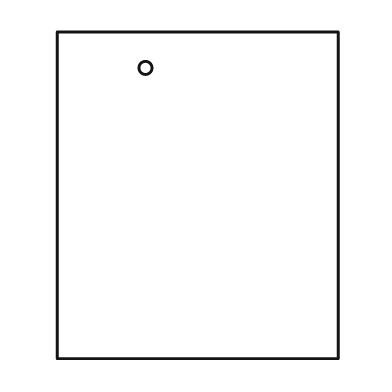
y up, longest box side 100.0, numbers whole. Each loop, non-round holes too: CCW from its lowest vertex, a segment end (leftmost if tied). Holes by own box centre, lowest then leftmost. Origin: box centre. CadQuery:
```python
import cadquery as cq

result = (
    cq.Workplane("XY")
    .moveTo(-43.0, -50.0)
    .lineTo(43.0, -50.0)
    .lineTo(43.0, 50.0)
    .lineTo(-43.0, 50.0)
    .close()
    .moveTo(-16.0, 39.0)
    .circle(2.0)
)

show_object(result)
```